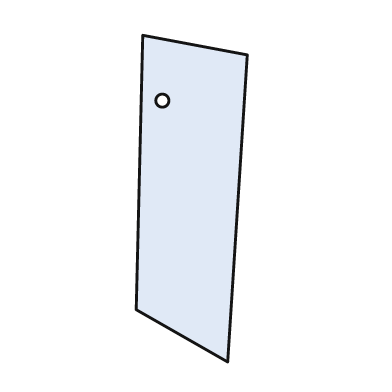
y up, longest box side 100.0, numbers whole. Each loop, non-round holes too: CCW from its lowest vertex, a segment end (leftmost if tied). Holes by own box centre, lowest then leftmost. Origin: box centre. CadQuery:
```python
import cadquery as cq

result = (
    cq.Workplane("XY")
    .moveTo(11.0, -50.0)
    .lineTo(17.0, 44.0)
    .lineTo(-15.0, 50.0)
    .lineTo(-17.0, -34.0)
    .close()
    .moveTo(-9.0, 30.0)
    .circle(2.0)
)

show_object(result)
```